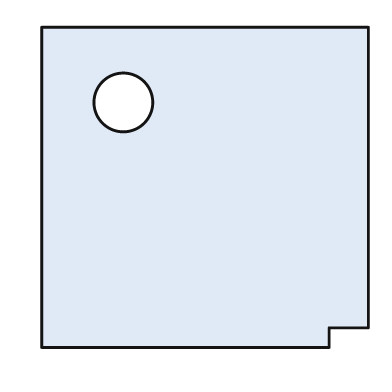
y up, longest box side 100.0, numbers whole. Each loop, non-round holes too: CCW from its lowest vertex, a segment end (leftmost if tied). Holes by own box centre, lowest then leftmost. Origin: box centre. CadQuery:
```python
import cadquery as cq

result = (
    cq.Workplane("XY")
    .moveTo(-50.0, -49.0)
    .lineTo(38.0, -49.0)
    .lineTo(38.0, -43.0)
    .lineTo(50.0, -43.0)
    .lineTo(50.0, 49.0)
    .lineTo(-50.0, 49.0)
    .close()
    .moveTo(-25.0, 26.0)
    .circle(9.0)
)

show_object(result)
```